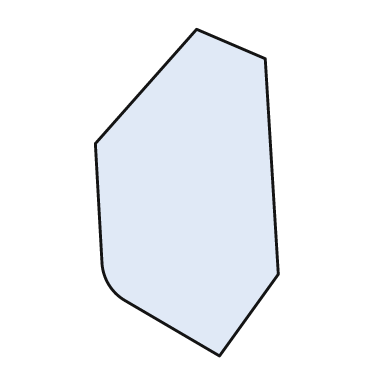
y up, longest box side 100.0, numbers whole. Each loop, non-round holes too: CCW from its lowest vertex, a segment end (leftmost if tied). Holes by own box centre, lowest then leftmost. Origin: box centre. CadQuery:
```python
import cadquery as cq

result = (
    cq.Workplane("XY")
    .moveTo(10.0, -50.0)
    .lineTo(28.0, -25.0)
    .lineTo(24.0, 41.0)
    .lineTo(3.0, 50.0)
    .lineTo(-28.0, 15.0)
    .lineTo(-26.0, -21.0)
    .threePointArc((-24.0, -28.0), (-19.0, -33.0))
    .close()
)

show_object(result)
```